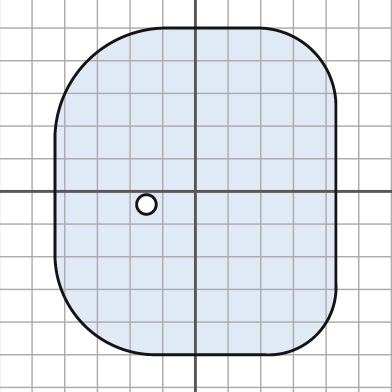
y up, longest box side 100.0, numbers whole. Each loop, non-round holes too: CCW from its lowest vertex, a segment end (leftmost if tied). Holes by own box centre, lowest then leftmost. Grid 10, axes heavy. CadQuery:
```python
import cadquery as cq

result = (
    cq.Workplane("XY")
    .moveTo(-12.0, -50.0)
    .lineTo(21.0, -50.0)
    .threePointArc((37.0, -44.0), (43.0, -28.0))
    .lineTo(43.0, 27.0)
    .threePointArc((36.0, 43.0), (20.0, 50.0))
    .lineTo(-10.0, 50.0)
    .threePointArc((-33.0, 40.0), (-43.0, 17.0))
    .lineTo(-43.0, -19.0)
    .threePointArc((-34.0, -41.0), (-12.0, -50.0))
    .close()
    .moveTo(-15.0, -4.0)
    .circle(3.0)
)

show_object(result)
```